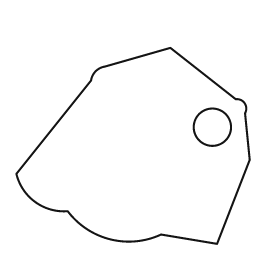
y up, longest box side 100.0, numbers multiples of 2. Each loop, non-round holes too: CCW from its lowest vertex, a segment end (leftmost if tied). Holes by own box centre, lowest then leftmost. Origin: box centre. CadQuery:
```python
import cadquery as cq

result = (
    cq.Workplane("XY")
    .moveTo(36.0, -42.0)
    .lineTo(50.0, -6.0)
    .lineTo(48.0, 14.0)
    .threePointArc((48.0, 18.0), (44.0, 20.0))
    .lineTo(16.0, 42.0)
    .lineTo(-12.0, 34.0)
    .threePointArc((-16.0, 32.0), (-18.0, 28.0))
    .lineTo(-50.0, -12.0)
    .threePointArc((-42.0, -24.0), (-28.0, -28.0))
    .threePointArc((-10.0, -40.0), (12.0, -38.0))
    .close()
    .moveTo(34.0, 8.0)
    .circle(8.0)
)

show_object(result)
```